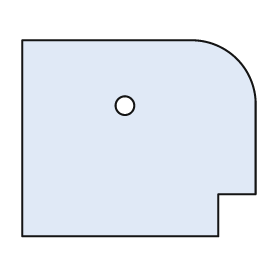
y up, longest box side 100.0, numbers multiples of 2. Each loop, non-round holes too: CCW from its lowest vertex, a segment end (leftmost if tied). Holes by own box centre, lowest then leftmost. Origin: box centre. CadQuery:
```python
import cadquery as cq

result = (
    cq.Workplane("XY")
    .moveTo(-50.0, -42.0)
    .lineTo(34.0, -42.0)
    .lineTo(34.0, -24.0)
    .lineTo(50.0, -24.0)
    .lineTo(50.0, 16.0)
    .threePointArc((42.0, 34.0), (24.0, 42.0))
    .lineTo(-50.0, 42.0)
    .close()
    .moveTo(-6.0, 14.0)
    .circle(4.0)
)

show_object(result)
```